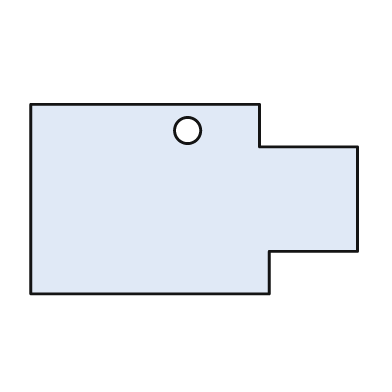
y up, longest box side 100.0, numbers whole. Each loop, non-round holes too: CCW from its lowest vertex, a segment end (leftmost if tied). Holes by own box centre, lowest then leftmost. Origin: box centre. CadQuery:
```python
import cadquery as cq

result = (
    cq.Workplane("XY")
    .moveTo(-50.0, -29.0)
    .lineTo(23.0, -29.0)
    .lineTo(23.0, -16.0)
    .lineTo(50.0, -16.0)
    .lineTo(50.0, 16.0)
    .lineTo(20.0, 16.0)
    .lineTo(20.0, 29.0)
    .lineTo(-50.0, 29.0)
    .close()
    .moveTo(-2.0, 21.0)
    .circle(4.0)
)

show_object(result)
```